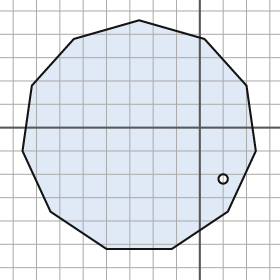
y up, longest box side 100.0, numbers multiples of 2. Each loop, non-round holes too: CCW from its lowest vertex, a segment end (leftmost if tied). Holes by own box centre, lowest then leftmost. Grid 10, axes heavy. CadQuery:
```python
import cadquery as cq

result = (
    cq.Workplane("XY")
    .moveTo(-40.0, -52.0)
    .lineTo(-12.0, -52.0)
    .lineTo(12.0, -36.0)
    .lineTo(24.0, -10.0)
    .lineTo(20.0, 18.0)
    .lineTo(2.0, 38.0)
    .lineTo(-26.0, 46.0)
    .lineTo(-54.0, 38.0)
    .lineTo(-72.0, 18.0)
    .lineTo(-76.0, -10.0)
    .lineTo(-64.0, -36.0)
    .close()
    .moveTo(10.0, -22.0)
    .circle(2.0)
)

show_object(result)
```